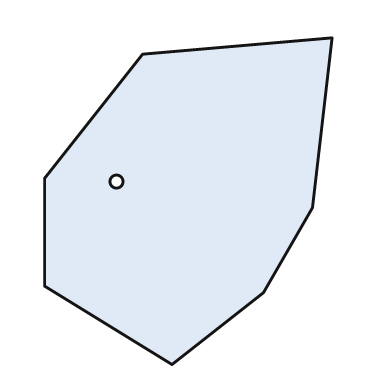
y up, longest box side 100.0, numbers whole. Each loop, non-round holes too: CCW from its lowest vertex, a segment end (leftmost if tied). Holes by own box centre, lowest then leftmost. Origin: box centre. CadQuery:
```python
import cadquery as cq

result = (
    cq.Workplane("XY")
    .moveTo(-5.0, -50.0)
    .lineTo(23.0, -28.0)
    .lineTo(38.0, -2.0)
    .lineTo(44.0, 50.0)
    .lineTo(-14.0, 45.0)
    .lineTo(-44.0, 7.0)
    .lineTo(-44.0, -26.0)
    .close()
    .moveTo(-22.0, 6.0)
    .circle(2.0)
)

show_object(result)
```